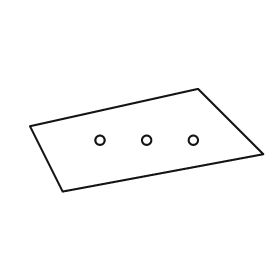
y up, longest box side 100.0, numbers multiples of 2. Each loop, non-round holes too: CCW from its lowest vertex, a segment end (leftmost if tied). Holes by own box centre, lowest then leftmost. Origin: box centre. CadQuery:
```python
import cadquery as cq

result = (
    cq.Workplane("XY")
    .moveTo(-36.0, -22.0)
    .lineTo(50.0, -6.0)
    .lineTo(22.0, 22.0)
    .lineTo(-50.0, 6.0)
    .close()
    .moveTo(-20.0, 0.0)
    .circle(2.0)
    .moveTo(0.0, 0.0)
    .circle(2.0)
    .moveTo(20.0, 0.0)
    .circle(2.0)
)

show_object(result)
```